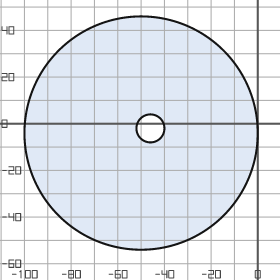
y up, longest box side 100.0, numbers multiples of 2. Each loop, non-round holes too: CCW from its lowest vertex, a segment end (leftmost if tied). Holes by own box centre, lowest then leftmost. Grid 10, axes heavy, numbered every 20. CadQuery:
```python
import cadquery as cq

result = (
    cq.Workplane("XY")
    .moveTo(-50.0, -4.0)
    .circle(50.0)
    .moveTo(-46.0, -2.0)
    .circle(6.0)
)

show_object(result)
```